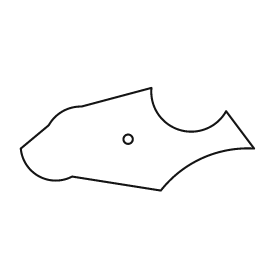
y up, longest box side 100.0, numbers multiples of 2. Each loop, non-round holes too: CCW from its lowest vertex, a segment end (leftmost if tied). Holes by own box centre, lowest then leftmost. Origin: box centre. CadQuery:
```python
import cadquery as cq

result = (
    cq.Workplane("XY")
    .moveTo(10.0, -22.0)
    .threePointArc((28.0, -8.0), (50.0, -4.0))
    .lineTo(38.0, 12.0)
    .threePointArc((18.0, 4.0), (6.0, 22.0))
    .lineTo(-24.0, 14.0)
    .threePointArc((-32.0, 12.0), (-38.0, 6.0))
    .lineTo(-50.0, -4.0)
    .threePointArc((-42.0, -16.0), (-28.0, -16.0))
    .close()
    .moveTo(-4.0, 0.0)
    .circle(2.0)
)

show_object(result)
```